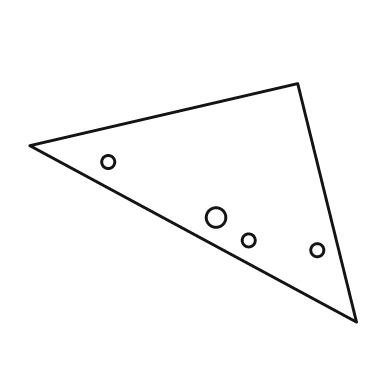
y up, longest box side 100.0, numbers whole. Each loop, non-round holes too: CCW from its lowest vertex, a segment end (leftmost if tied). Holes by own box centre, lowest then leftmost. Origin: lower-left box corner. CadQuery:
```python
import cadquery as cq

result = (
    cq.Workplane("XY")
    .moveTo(100.0, 0.0)
    .lineTo(82.0, 73.0)
    .lineTo(0.0, 54.0)
    .close()
    .moveTo(88.0, 22.0)
    .circle(2.0)
    .moveTo(67.0, 25.0)
    .circle(2.0)
    .moveTo(57.0, 32.0)
    .circle(3.0)
    .moveTo(24.0, 49.0)
    .circle(2.0)
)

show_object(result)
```